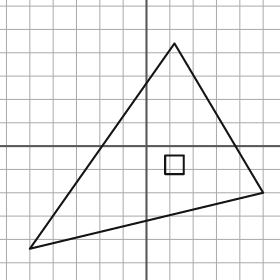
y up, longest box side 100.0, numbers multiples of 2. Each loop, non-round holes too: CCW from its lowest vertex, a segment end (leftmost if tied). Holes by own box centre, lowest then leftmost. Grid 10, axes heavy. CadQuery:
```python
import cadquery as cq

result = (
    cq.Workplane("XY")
    .moveTo(-50.0, -44.0)
    .lineTo(50.0, -20.0)
    .lineTo(12.0, 44.0)
    .close()
    .moveTo(8.0, -12.0)
    .lineTo(16.0, -12.0)
    .lineTo(16.0, -4.0)
    .lineTo(8.0, -4.0)
    .close()
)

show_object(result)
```